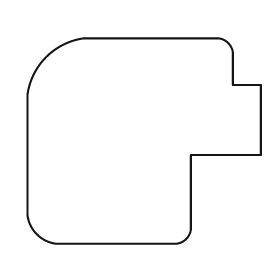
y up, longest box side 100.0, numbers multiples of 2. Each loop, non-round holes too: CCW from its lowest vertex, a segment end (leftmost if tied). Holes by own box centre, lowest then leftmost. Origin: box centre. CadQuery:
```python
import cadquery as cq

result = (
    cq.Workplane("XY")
    .moveTo(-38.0, -44.0)
    .lineTo(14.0, -44.0)
    .threePointArc((18.0, -42.0), (20.0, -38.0))
    .lineTo(20.0, -6.0)
    .lineTo(50.0, -6.0)
    .lineTo(50.0, 24.0)
    .lineTo(38.0, 24.0)
    .lineTo(38.0, 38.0)
    .threePointArc((36.0, 42.0), (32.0, 44.0))
    .lineTo(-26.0, 44.0)
    .threePointArc((-42.0, 36.0), (-50.0, 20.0))
    .lineTo(-50.0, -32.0)
    .threePointArc((-46.0, -40.0), (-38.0, -44.0))
    .close()
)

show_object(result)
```